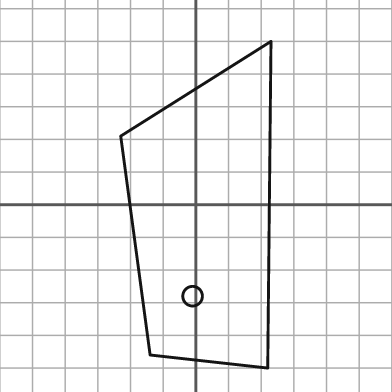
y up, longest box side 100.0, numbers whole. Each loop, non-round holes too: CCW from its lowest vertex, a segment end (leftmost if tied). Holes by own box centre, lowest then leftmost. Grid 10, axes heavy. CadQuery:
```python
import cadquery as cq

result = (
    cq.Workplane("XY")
    .moveTo(22.0, -50.0)
    .lineTo(23.0, 50.0)
    .lineTo(-23.0, 21.0)
    .lineTo(-14.0, -46.0)
    .close()
    .moveTo(-1.0, -28.0)
    .circle(3.0)
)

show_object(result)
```